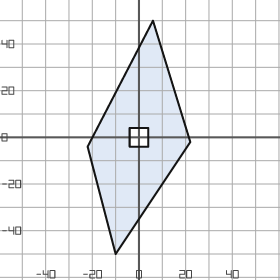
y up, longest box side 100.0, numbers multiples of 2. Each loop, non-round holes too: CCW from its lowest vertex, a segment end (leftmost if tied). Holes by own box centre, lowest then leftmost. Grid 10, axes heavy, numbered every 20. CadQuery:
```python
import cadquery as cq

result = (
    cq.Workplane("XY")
    .moveTo(-10.0, -50.0)
    .lineTo(22.0, -2.0)
    .lineTo(6.0, 50.0)
    .lineTo(-22.0, -4.0)
    .close()
    .moveTo(-4.0, -4.0)
    .lineTo(4.0, -4.0)
    .lineTo(4.0, 4.0)
    .lineTo(-4.0, 4.0)
    .close()
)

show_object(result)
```